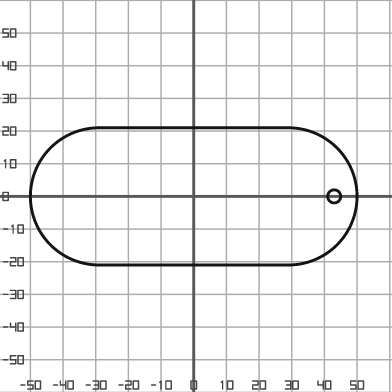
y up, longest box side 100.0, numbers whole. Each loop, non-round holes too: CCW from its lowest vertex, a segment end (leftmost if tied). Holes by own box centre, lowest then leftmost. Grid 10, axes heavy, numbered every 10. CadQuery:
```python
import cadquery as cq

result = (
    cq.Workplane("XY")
    .moveTo(-29.0, -21.0)
    .lineTo(29.0, -21.0)
    .threePointArc((50.0, 0.0), (29.0, 21.0))
    .lineTo(-29.0, 21.0)
    .threePointArc((-50.0, 0.0), (-29.0, -21.0))
    .close()
    .moveTo(43.0, 0.0)
    .circle(2.0)
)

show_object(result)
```